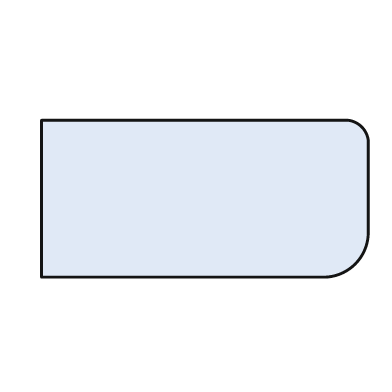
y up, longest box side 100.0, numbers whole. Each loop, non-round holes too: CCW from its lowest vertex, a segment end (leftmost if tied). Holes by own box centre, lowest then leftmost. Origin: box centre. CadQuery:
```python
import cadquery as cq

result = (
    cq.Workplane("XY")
    .moveTo(-50.0, -24.0)
    .lineTo(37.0, -24.0)
    .threePointArc((46.0, -20.0), (50.0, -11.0))
    .lineTo(50.0, 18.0)
    .threePointArc((48.0, 22.0), (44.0, 24.0))
    .lineTo(-50.0, 24.0)
    .close()
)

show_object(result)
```